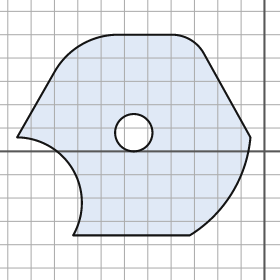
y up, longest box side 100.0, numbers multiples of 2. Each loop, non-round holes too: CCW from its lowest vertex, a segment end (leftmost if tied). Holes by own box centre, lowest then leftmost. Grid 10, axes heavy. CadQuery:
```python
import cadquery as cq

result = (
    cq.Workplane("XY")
    .moveTo(-82.0, -36.0)
    .lineTo(-32.0, -36.0)
    .threePointArc((-14.0, -18.0), (-6.0, 6.0))
    .lineTo(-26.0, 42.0)
    .threePointArc((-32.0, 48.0), (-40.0, 50.0))
    .lineTo(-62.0, 50.0)
    .threePointArc((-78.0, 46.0), (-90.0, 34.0))
    .lineTo(-106.0, 6.0)
    .threePointArc((-82.0, -8.0), (-82.0, -36.0))
    .close()
    .moveTo(-56.0, 8.0)
    .circle(8.0)
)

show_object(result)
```